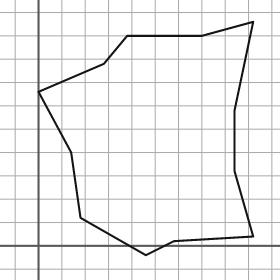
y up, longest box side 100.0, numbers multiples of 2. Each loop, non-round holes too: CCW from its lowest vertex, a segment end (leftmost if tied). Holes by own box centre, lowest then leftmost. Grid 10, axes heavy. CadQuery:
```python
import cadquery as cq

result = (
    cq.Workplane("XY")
    .moveTo(46.0, -4.0)
    .lineTo(58.0, 2.0)
    .lineTo(92.0, 4.0)
    .lineTo(84.0, 32.0)
    .lineTo(84.0, 58.0)
    .lineTo(92.0, 96.0)
    .lineTo(70.0, 90.0)
    .lineTo(38.0, 90.0)
    .lineTo(28.0, 78.0)
    .lineTo(0.0, 66.0)
    .lineTo(14.0, 40.0)
    .lineTo(18.0, 12.0)
    .close()
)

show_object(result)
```